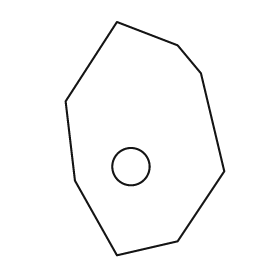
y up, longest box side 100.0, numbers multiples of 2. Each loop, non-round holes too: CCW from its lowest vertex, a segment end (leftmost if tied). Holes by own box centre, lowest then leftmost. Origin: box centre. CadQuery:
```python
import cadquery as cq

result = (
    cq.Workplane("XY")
    .moveTo(-12.0, -50.0)
    .lineTo(14.0, -44.0)
    .lineTo(34.0, -14.0)
    .lineTo(24.0, 28.0)
    .lineTo(14.0, 40.0)
    .lineTo(-12.0, 50.0)
    .lineTo(-34.0, 16.0)
    .lineTo(-30.0, -18.0)
    .close()
    .moveTo(-6.0, -12.0)
    .circle(8.0)
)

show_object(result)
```